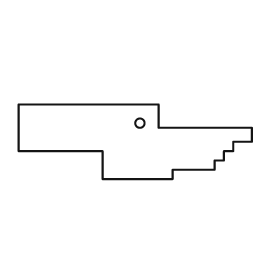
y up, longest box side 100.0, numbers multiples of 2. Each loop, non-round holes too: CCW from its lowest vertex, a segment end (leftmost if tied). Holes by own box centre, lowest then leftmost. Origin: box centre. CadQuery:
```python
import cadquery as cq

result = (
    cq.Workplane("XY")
    .moveTo(-14.0, -16.0)
    .lineTo(16.0, -16.0)
    .lineTo(16.0, -12.0)
    .lineTo(34.0, -12.0)
    .lineTo(34.0, -8.0)
    .lineTo(38.0, -8.0)
    .lineTo(38.0, -4.0)
    .lineTo(42.0, -4.0)
    .lineTo(42.0, 0.0)
    .lineTo(50.0, 0.0)
    .lineTo(50.0, 6.0)
    .lineTo(10.0, 6.0)
    .lineTo(10.0, 16.0)
    .lineTo(-50.0, 16.0)
    .lineTo(-50.0, -4.0)
    .lineTo(-14.0, -4.0)
    .close()
    .moveTo(2.0, 8.0)
    .circle(2.0)
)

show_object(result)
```